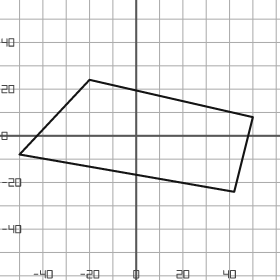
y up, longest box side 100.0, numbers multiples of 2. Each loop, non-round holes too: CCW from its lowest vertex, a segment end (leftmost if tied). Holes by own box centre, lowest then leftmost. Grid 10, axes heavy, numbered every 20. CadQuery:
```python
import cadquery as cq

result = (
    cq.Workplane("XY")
    .moveTo(42.0, -24.0)
    .lineTo(50.0, 8.0)
    .lineTo(-20.0, 24.0)
    .lineTo(-50.0, -8.0)
    .close()
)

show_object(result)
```